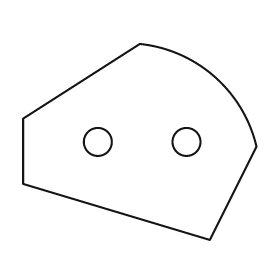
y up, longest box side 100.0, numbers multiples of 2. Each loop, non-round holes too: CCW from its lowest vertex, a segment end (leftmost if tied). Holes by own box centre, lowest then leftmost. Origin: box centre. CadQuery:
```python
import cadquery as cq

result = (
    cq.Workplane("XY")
    .moveTo(30.0, -42.0)
    .lineTo(50.0, -2.0)
    .threePointArc((32.0, 28.0), (0.0, 42.0))
    .lineTo(-50.0, 10.0)
    .lineTo(-50.0, -18.0)
    .close()
    .moveTo(-18.0, 0.0)
    .circle(6.0)
    .moveTo(20.0, 0.0)
    .circle(6.0)
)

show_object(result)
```